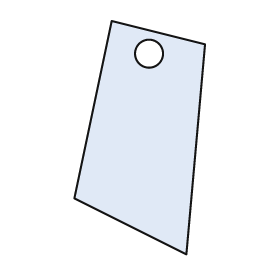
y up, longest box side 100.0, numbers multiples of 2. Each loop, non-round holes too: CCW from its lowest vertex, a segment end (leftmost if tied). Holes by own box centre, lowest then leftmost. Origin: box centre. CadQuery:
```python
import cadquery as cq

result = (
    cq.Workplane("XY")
    .moveTo(20.0, -50.0)
    .lineTo(28.0, 40.0)
    .lineTo(-12.0, 50.0)
    .lineTo(-28.0, -26.0)
    .close()
    .moveTo(4.0, 36.0)
    .circle(6.0)
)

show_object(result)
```